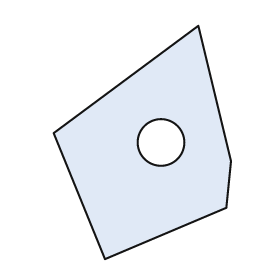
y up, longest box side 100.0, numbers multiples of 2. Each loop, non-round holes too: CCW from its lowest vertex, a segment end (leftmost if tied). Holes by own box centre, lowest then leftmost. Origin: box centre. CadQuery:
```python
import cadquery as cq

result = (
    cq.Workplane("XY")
    .moveTo(-16.0, -50.0)
    .lineTo(36.0, -28.0)
    .lineTo(38.0, -8.0)
    .lineTo(24.0, 50.0)
    .lineTo(-38.0, 4.0)
    .close()
    .moveTo(8.0, 0.0)
    .circle(10.0)
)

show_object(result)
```